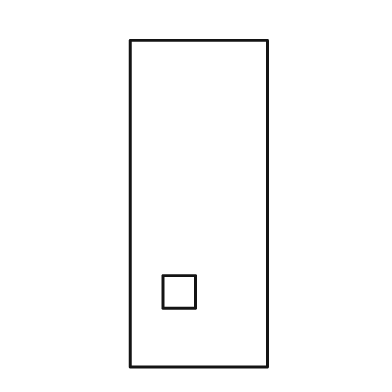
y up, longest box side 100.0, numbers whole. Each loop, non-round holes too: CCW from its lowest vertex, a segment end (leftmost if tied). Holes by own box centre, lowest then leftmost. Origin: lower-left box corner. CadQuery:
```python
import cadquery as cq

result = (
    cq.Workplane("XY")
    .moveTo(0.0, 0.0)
    .lineTo(42.0, 0.0)
    .lineTo(42.0, 100.0)
    .lineTo(0.0, 100.0)
    .close()
    .moveTo(10.0, 18.0)
    .lineTo(20.0, 18.0)
    .lineTo(20.0, 28.0)
    .lineTo(10.0, 28.0)
    .close()
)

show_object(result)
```